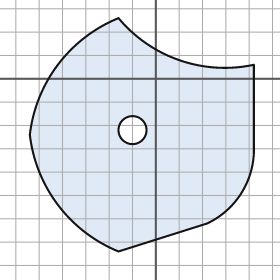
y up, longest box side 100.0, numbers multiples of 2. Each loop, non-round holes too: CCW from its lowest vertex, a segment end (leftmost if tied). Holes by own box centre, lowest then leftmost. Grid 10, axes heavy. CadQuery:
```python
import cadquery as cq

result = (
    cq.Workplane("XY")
    .moveTo(-16.0, -74.0)
    .lineTo(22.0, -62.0)
    .threePointArc((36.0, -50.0), (42.0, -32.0))
    .lineTo(42.0, 6.0)
    .threePointArc((10.0, 8.0), (-16.0, 26.0))
    .threePointArc((-42.0, 6.0), (-54.0, -24.0))
    .threePointArc((-42.0, -54.0), (-16.0, -74.0))
    .close()
    .moveTo(-10.0, -22.0)
    .circle(6.0)
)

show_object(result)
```